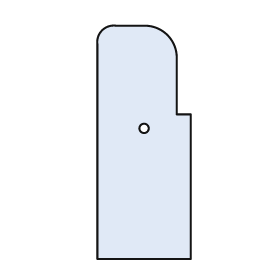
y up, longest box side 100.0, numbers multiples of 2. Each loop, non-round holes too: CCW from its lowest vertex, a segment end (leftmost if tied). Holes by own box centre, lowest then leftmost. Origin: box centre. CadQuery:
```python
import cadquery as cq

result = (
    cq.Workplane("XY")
    .moveTo(-20.0, -50.0)
    .lineTo(20.0, -50.0)
    .lineTo(20.0, 12.0)
    .lineTo(14.0, 12.0)
    .lineTo(14.0, 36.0)
    .threePointArc((10.0, 46.0), (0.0, 50.0))
    .lineTo(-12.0, 50.0)
    .threePointArc((-18.0, 48.0), (-20.0, 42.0))
    .close()
    .moveTo(0.0, 6.0)
    .circle(2.0)
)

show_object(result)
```